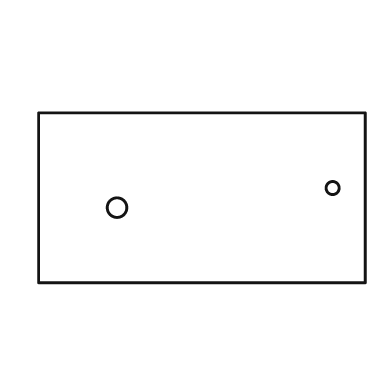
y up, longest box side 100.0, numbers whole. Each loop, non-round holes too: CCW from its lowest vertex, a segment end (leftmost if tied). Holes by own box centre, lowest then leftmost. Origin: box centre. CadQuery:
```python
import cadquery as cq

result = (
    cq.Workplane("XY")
    .moveTo(-50.0, -26.0)
    .lineTo(50.0, -26.0)
    .lineTo(50.0, 26.0)
    .lineTo(-50.0, 26.0)
    .close()
    .moveTo(-26.0, -3.0)
    .circle(3.0)
    .moveTo(40.0, 3.0)
    .circle(2.0)
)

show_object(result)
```